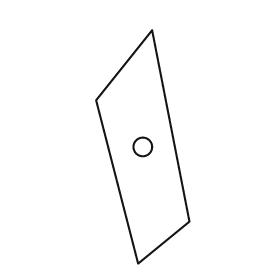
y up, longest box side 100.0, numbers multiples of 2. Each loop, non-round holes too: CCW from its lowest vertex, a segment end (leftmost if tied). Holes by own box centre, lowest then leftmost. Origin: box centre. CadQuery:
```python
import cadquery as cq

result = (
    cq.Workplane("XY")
    .moveTo(-2.0, -50.0)
    .lineTo(20.0, -32.0)
    .lineTo(4.0, 50.0)
    .lineTo(-20.0, 20.0)
    .close()
    .moveTo(0.0, 0.0)
    .circle(4.0)
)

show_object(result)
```